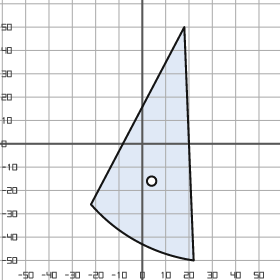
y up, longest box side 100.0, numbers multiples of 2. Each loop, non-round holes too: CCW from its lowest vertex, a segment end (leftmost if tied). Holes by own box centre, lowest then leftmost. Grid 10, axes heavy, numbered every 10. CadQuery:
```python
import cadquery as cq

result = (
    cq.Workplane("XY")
    .moveTo(22.0, -50.0)
    .lineTo(18.0, 50.0)
    .lineTo(-22.0, -26.0)
    .threePointArc((-2.0, -42.0), (22.0, -50.0))
    .close()
    .moveTo(4.0, -16.0)
    .circle(2.0)
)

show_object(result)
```